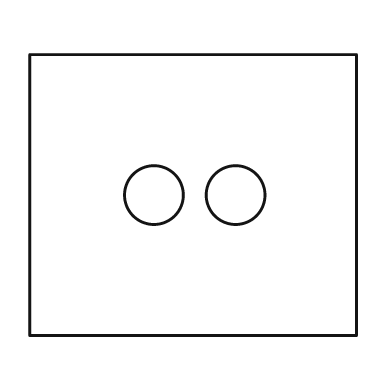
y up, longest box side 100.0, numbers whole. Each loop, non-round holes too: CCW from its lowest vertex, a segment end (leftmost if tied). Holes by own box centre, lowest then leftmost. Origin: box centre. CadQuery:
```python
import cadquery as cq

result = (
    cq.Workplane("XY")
    .moveTo(-50.0, -43.0)
    .lineTo(50.0, -43.0)
    .lineTo(50.0, 43.0)
    .lineTo(-50.0, 43.0)
    .close()
    .moveTo(-12.0, 0.0)
    .circle(9.0)
    .moveTo(13.0, 0.0)
    .circle(9.0)
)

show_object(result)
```